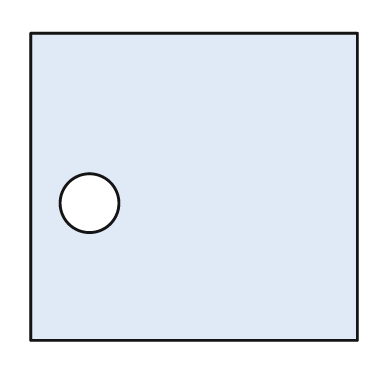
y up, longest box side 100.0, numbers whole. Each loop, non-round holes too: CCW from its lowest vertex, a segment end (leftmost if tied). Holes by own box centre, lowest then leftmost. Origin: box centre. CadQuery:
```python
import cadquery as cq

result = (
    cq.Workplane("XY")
    .moveTo(-50.0, -47.0)
    .lineTo(50.0, -47.0)
    .lineTo(50.0, 47.0)
    .lineTo(-50.0, 47.0)
    .close()
    .moveTo(-32.0, -5.0)
    .circle(9.0)
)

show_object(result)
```